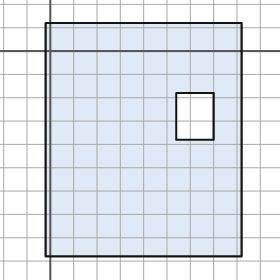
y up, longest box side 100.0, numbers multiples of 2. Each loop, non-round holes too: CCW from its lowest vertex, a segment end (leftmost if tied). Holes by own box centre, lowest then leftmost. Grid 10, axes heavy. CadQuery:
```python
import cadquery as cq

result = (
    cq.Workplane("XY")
    .moveTo(-2.0, -88.0)
    .lineTo(82.0, -88.0)
    .lineTo(82.0, 12.0)
    .lineTo(-2.0, 12.0)
    .close()
    .moveTo(54.0, -38.0)
    .lineTo(70.0, -38.0)
    .lineTo(70.0, -18.0)
    .lineTo(54.0, -18.0)
    .close()
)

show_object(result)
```